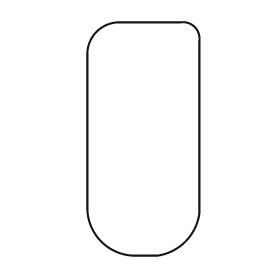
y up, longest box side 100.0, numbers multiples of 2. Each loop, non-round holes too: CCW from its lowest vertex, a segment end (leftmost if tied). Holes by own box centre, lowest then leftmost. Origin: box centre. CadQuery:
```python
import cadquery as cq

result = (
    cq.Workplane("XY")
    .moveTo(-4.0, -50.0)
    .lineTo(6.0, -50.0)
    .threePointArc((18.0, -44.0), (24.0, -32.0))
    .lineTo(24.0, 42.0)
    .threePointArc((22.0, 48.0), (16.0, 50.0))
    .lineTo(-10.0, 50.0)
    .threePointArc((-20.0, 46.0), (-24.0, 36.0))
    .lineTo(-24.0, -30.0)
    .threePointArc((-18.0, -44.0), (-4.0, -50.0))
    .close()
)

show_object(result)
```